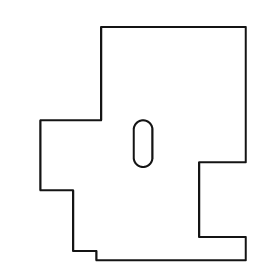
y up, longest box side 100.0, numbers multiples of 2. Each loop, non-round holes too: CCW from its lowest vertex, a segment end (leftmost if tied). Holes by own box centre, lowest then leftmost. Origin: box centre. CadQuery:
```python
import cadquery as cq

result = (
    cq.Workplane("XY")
    .moveTo(-20.0, -50.0)
    .lineTo(44.0, -50.0)
    .lineTo(44.0, -40.0)
    .lineTo(24.0, -40.0)
    .lineTo(24.0, -8.0)
    .lineTo(44.0, -8.0)
    .lineTo(44.0, 50.0)
    .lineTo(-18.0, 50.0)
    .lineTo(-18.0, 10.0)
    .lineTo(-44.0, 10.0)
    .lineTo(-44.0, -20.0)
    .lineTo(-30.0, -20.0)
    .lineTo(-30.0, -46.0)
    .lineTo(-20.0, -46.0)
    .close()
    .moveTo(-4.0, -6.0)
    .threePointArc((0.0, -10.0), (4.0, -6.0))
    .lineTo(4.0, 6.0)
    .threePointArc((0.0, 10.0), (-4.0, 6.0))
    .close()
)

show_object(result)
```